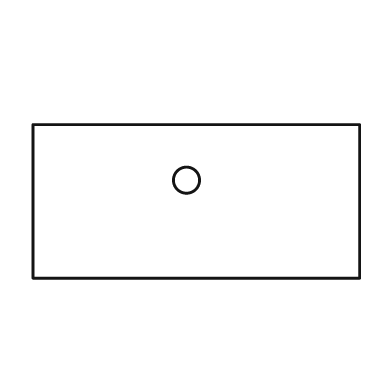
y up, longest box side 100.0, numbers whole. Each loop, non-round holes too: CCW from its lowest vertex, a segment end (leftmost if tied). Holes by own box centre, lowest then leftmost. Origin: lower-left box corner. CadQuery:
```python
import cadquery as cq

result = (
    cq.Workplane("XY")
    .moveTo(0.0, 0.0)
    .lineTo(100.0, 0.0)
    .lineTo(100.0, 47.0)
    .lineTo(0.0, 47.0)
    .close()
    .moveTo(47.0, 30.0)
    .circle(4.0)
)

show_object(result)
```